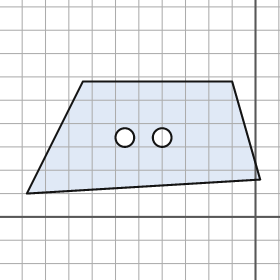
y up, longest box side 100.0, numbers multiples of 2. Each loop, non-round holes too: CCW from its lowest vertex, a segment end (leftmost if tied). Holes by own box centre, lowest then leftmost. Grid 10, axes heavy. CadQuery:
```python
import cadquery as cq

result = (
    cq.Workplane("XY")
    .moveTo(-98.0, 10.0)
    .lineTo(2.0, 16.0)
    .lineTo(-10.0, 58.0)
    .lineTo(-74.0, 58.0)
    .close()
    .moveTo(-56.0, 34.0)
    .circle(4.0)
    .moveTo(-40.0, 34.0)
    .circle(4.0)
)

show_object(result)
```